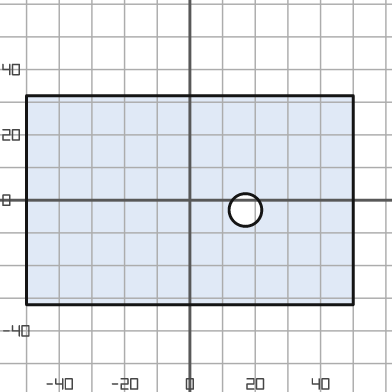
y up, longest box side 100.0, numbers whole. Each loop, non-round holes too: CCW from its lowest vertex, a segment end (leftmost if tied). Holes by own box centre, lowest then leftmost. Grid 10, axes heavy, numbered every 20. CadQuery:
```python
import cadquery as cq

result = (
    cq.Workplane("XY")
    .moveTo(-50.0, -32.0)
    .lineTo(50.0, -32.0)
    .lineTo(50.0, 32.0)
    .lineTo(-50.0, 32.0)
    .close()
    .moveTo(17.0, -3.0)
    .circle(5.0)
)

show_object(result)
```